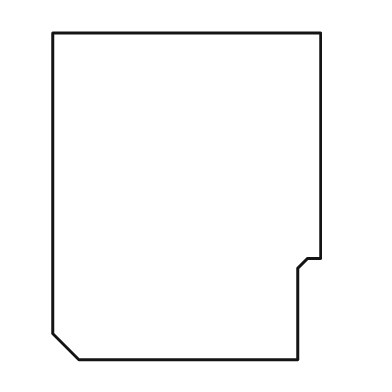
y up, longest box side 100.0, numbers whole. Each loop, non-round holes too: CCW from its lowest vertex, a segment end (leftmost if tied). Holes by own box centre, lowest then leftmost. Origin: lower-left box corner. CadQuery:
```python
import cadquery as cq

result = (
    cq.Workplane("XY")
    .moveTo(8.0, 0.0)
    .lineTo(75.0, 0.0)
    .lineTo(75.0, 28.0)
    .lineTo(78.0, 31.0)
    .lineTo(82.0, 31.0)
    .lineTo(82.0, 100.0)
    .lineTo(0.0, 100.0)
    .lineTo(0.0, 8.0)
    .close()
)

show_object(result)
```